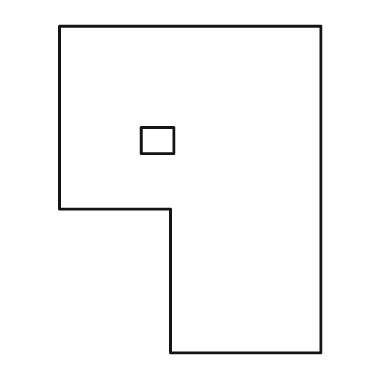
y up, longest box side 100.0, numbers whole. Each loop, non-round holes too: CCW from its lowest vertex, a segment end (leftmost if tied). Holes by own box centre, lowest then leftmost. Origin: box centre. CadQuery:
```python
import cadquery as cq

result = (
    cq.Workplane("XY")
    .moveTo(-6.0, -50.0)
    .lineTo(40.0, -50.0)
    .lineTo(40.0, 50.0)
    .lineTo(-40.0, 50.0)
    .lineTo(-40.0, -6.0)
    .lineTo(-6.0, -6.0)
    .close()
    .moveTo(-15.0, 11.0)
    .lineTo(-5.0, 11.0)
    .lineTo(-5.0, 19.0)
    .lineTo(-15.0, 19.0)
    .close()
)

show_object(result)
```